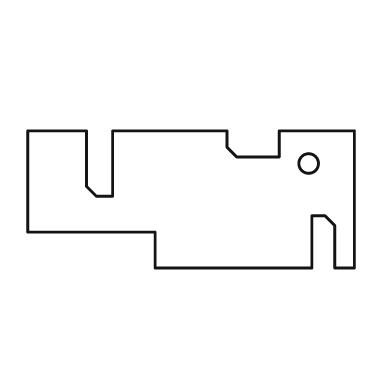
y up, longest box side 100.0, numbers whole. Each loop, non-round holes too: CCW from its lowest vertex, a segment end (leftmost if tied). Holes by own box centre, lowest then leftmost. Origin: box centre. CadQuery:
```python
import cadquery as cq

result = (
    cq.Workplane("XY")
    .moveTo(-11.0, -21.0)
    .lineTo(37.0, -21.0)
    .lineTo(37.0, -5.0)
    .lineTo(41.0, -5.0)
    .lineTo(44.0, -8.0)
    .lineTo(44.0, -21.0)
    .lineTo(50.0, -21.0)
    .lineTo(50.0, 21.0)
    .lineTo(27.0, 21.0)
    .lineTo(27.0, 13.0)
    .lineTo(14.0, 13.0)
    .lineTo(11.0, 16.0)
    .lineTo(11.0, 21.0)
    .lineTo(-24.0, 21.0)
    .lineTo(-24.0, 1.0)
    .lineTo(-29.0, 1.0)
    .lineTo(-32.0, 4.0)
    .lineTo(-32.0, 21.0)
    .lineTo(-50.0, 21.0)
    .lineTo(-50.0, -10.0)
    .lineTo(-11.0, -10.0)
    .close()
    .moveTo(36.0, 11.0)
    .circle(3.0)
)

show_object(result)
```